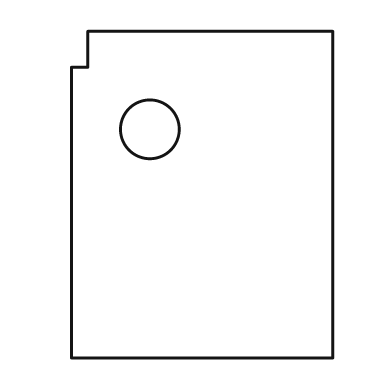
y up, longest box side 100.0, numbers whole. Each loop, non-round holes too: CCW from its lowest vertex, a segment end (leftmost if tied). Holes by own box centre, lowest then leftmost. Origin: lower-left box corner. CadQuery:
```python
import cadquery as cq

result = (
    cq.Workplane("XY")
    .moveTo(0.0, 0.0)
    .lineTo(80.0, 0.0)
    .lineTo(80.0, 100.0)
    .lineTo(5.0, 100.0)
    .lineTo(5.0, 89.0)
    .lineTo(0.0, 89.0)
    .close()
    .moveTo(24.0, 70.0)
    .circle(9.0)
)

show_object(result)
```